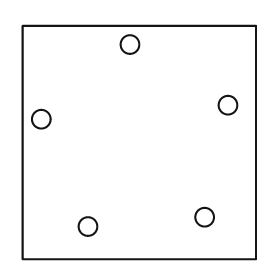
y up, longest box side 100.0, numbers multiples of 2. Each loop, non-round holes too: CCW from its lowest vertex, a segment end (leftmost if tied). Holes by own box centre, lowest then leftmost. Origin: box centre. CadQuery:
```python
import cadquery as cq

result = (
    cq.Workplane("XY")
    .moveTo(-50.0, -50.0)
    .lineTo(50.0, -50.0)
    .lineTo(50.0, 50.0)
    .lineTo(-50.0, 50.0)
    .close()
    .moveTo(-22.0, -36.0)
    .circle(4.0)
    .moveTo(28.0, -32.0)
    .circle(4.0)
    .moveTo(-42.0, 10.0)
    .circle(4.0)
    .moveTo(38.0, 16.0)
    .circle(4.0)
    .moveTo(-4.0, 42.0)
    .circle(4.0)
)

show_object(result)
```